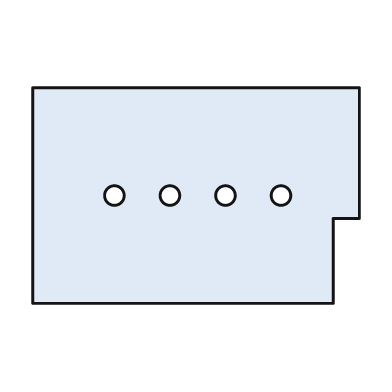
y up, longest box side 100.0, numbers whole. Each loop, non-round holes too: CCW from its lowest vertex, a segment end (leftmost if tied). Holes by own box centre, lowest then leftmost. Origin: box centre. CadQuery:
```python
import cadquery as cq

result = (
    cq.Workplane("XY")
    .moveTo(-50.0, -33.0)
    .lineTo(42.0, -33.0)
    .lineTo(42.0, -7.0)
    .lineTo(50.0, -7.0)
    .lineTo(50.0, 33.0)
    .lineTo(-50.0, 33.0)
    .close()
    .moveTo(-25.0, 0.0)
    .circle(3.0)
    .moveTo(-8.0, 0.0)
    .circle(3.0)
    .moveTo(9.0, 0.0)
    .circle(3.0)
    .moveTo(26.0, 0.0)
    .circle(3.0)
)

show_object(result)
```